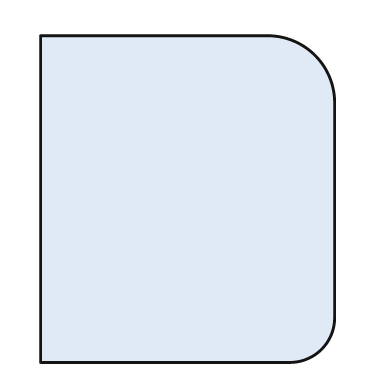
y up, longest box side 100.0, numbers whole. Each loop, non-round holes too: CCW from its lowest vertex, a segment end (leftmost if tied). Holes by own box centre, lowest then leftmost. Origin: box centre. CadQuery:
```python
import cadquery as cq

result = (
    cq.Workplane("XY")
    .moveTo(-45.0, -50.0)
    .lineTo(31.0, -50.0)
    .threePointArc((41.0, -46.0), (45.0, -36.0))
    .lineTo(45.0, 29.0)
    .threePointArc((39.0, 44.0), (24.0, 50.0))
    .lineTo(-45.0, 50.0)
    .close()
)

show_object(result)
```